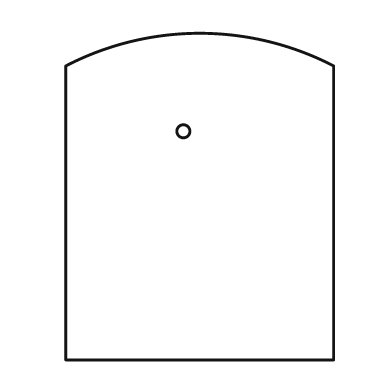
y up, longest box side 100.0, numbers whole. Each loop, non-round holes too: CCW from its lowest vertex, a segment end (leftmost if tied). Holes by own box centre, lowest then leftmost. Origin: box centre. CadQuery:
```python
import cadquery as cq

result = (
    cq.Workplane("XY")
    .moveTo(-41.0, -50.0)
    .lineTo(41.0, -50.0)
    .lineTo(41.0, 40.0)
    .threePointArc((0.0, 50.0), (-41.0, 40.0))
    .close()
    .moveTo(-5.0, 20.0)
    .circle(2.0)
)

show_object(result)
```